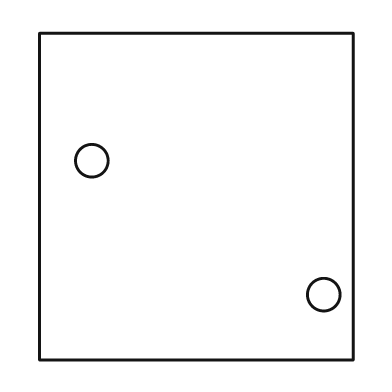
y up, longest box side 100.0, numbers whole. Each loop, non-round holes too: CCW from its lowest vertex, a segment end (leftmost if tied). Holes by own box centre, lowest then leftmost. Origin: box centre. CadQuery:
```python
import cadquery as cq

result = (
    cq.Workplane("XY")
    .moveTo(-48.0, -50.0)
    .lineTo(48.0, -50.0)
    .lineTo(48.0, 50.0)
    .lineTo(-48.0, 50.0)
    .close()
    .moveTo(39.0, -30.0)
    .circle(5.0)
    .moveTo(-32.0, 11.0)
    .circle(5.0)
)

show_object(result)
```